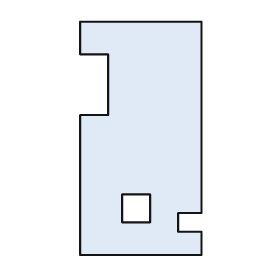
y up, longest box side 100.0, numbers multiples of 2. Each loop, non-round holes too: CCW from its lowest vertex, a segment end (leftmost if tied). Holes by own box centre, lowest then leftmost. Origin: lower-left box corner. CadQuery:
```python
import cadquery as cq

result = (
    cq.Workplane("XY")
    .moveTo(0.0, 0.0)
    .lineTo(52.0, 0.0)
    .lineTo(52.0, 10.0)
    .lineTo(42.0, 10.0)
    .lineTo(42.0, 18.0)
    .lineTo(52.0, 18.0)
    .lineTo(52.0, 100.0)
    .lineTo(0.0, 100.0)
    .lineTo(0.0, 86.0)
    .lineTo(12.0, 86.0)
    .lineTo(12.0, 60.0)
    .lineTo(0.0, 60.0)
    .close()
    .moveTo(18.0, 14.0)
    .lineTo(30.0, 14.0)
    .lineTo(30.0, 26.0)
    .lineTo(18.0, 26.0)
    .close()
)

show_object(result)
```